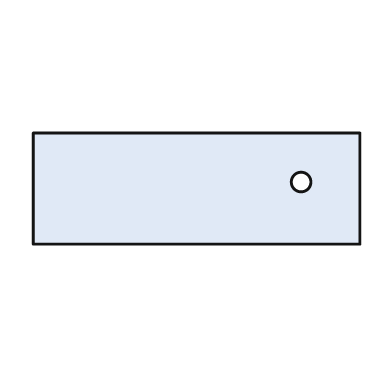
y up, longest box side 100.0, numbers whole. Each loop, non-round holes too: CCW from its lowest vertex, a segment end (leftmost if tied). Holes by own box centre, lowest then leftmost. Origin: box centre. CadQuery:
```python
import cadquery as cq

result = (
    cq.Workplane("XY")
    .moveTo(-50.0, -17.0)
    .lineTo(50.0, -17.0)
    .lineTo(50.0, 17.0)
    .lineTo(-50.0, 17.0)
    .close()
    .moveTo(32.0, 2.0)
    .circle(3.0)
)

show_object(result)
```